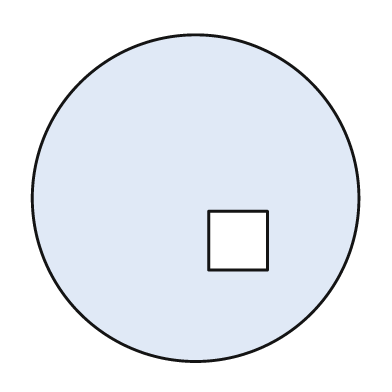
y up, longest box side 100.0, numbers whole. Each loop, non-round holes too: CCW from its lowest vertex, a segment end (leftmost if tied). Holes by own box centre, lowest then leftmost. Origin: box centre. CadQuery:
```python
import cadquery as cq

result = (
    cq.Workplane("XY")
    .moveTo(0.0, 0.0)
    .circle(50.0)
    .moveTo(4.0, -22.0)
    .lineTo(22.0, -22.0)
    .lineTo(22.0, -4.0)
    .lineTo(4.0, -4.0)
    .close()
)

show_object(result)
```